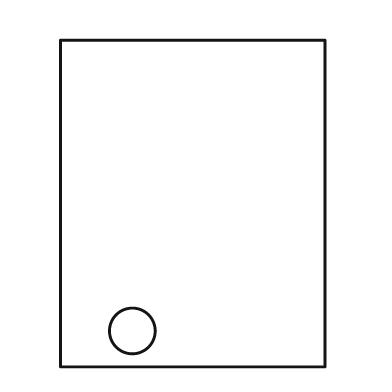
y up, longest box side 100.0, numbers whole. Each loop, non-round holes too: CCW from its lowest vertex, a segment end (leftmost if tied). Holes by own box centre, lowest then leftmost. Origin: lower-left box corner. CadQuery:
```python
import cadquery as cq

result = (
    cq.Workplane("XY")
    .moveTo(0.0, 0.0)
    .lineTo(81.0, 0.0)
    .lineTo(81.0, 100.0)
    .lineTo(0.0, 100.0)
    .close()
    .moveTo(22.0, 11.0)
    .circle(7.0)
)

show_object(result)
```